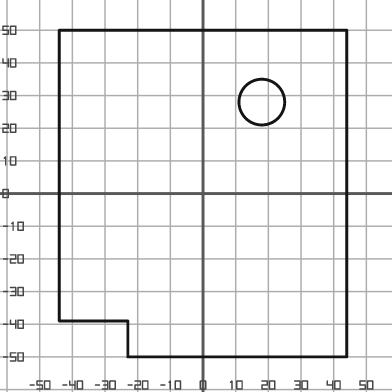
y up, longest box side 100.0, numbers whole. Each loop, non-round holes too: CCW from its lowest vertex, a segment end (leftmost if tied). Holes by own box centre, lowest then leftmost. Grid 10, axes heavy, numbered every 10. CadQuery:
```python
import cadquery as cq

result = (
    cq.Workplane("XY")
    .moveTo(-23.0, -50.0)
    .lineTo(44.0, -50.0)
    .lineTo(44.0, 50.0)
    .lineTo(-44.0, 50.0)
    .lineTo(-44.0, -39.0)
    .lineTo(-23.0, -39.0)
    .close()
    .moveTo(18.0, 28.0)
    .circle(7.0)
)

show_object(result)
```